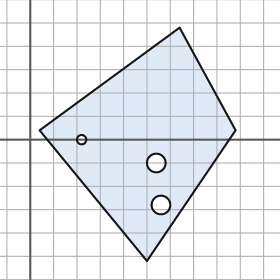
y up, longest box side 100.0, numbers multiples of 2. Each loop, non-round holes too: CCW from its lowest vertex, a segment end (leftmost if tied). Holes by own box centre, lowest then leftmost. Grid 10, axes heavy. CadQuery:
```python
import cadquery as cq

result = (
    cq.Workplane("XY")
    .moveTo(50.0, -52.0)
    .lineTo(88.0, 4.0)
    .lineTo(64.0, 48.0)
    .lineTo(4.0, 4.0)
    .close()
    .moveTo(56.0, -28.0)
    .circle(4.0)
    .moveTo(54.0, -10.0)
    .circle(4.0)
    .moveTo(22.0, 0.0)
    .circle(2.0)
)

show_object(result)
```